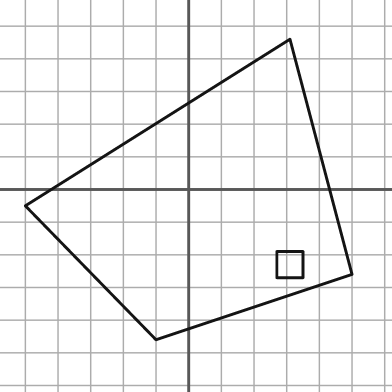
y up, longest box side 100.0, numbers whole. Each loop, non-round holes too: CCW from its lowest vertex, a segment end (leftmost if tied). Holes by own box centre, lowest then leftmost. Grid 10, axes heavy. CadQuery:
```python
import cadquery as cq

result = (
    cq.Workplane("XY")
    .moveTo(-10.0, -46.0)
    .lineTo(50.0, -26.0)
    .lineTo(31.0, 46.0)
    .lineTo(-50.0, -5.0)
    .close()
    .moveTo(27.0, -27.0)
    .lineTo(35.0, -27.0)
    .lineTo(35.0, -19.0)
    .lineTo(27.0, -19.0)
    .close()
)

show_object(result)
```